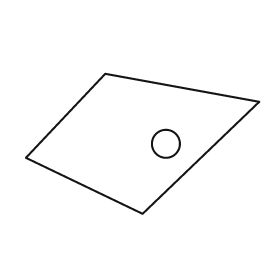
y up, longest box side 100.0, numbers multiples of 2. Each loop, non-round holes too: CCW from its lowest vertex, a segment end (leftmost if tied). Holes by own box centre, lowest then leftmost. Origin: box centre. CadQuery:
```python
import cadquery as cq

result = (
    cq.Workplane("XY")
    .moveTo(0.0, -30.0)
    .lineTo(50.0, 18.0)
    .lineTo(-16.0, 30.0)
    .lineTo(-50.0, -6.0)
    .close()
    .moveTo(10.0, 0.0)
    .circle(6.0)
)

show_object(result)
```